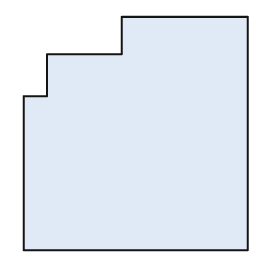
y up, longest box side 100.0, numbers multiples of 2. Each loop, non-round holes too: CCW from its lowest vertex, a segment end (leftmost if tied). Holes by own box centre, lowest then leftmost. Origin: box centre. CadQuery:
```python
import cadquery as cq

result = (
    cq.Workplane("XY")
    .moveTo(-48.0, -50.0)
    .lineTo(48.0, -50.0)
    .lineTo(48.0, 50.0)
    .lineTo(-6.0, 50.0)
    .lineTo(-6.0, 34.0)
    .lineTo(-38.0, 34.0)
    .lineTo(-38.0, 16.0)
    .lineTo(-48.0, 16.0)
    .close()
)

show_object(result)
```